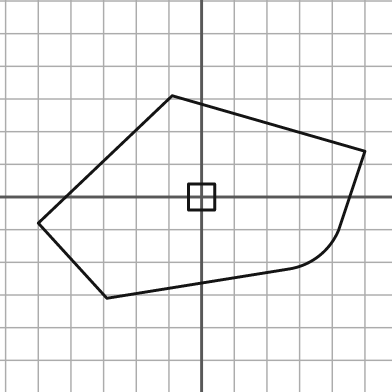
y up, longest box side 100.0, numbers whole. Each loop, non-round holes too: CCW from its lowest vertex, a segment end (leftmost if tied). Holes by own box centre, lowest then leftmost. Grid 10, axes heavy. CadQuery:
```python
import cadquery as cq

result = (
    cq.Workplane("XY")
    .moveTo(-29.0, -31.0)
    .lineTo(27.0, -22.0)
    .threePointArc((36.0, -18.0), (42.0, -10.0))
    .lineTo(50.0, 14.0)
    .lineTo(-9.0, 31.0)
    .lineTo(-50.0, -8.0)
    .close()
    .moveTo(-4.0, -4.0)
    .lineTo(4.0, -4.0)
    .lineTo(4.0, 4.0)
    .lineTo(-4.0, 4.0)
    .close()
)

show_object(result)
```